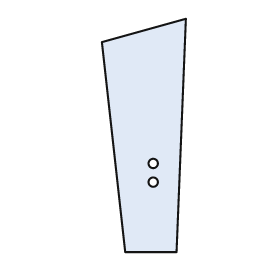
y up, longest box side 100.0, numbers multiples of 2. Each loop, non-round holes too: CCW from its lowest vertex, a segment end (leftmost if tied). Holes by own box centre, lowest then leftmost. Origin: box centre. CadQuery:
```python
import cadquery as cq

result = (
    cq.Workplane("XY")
    .moveTo(-8.0, -50.0)
    .lineTo(14.0, -50.0)
    .lineTo(18.0, 50.0)
    .lineTo(-18.0, 40.0)
    .close()
    .moveTo(4.0, -20.0)
    .circle(2.0)
    .moveTo(4.0, -12.0)
    .circle(2.0)
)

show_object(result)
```